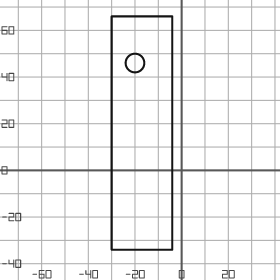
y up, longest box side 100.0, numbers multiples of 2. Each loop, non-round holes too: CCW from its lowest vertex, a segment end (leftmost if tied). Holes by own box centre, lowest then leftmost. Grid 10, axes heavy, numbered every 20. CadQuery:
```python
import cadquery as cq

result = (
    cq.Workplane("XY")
    .moveTo(-30.0, -34.0)
    .lineTo(-4.0, -34.0)
    .lineTo(-4.0, 66.0)
    .lineTo(-30.0, 66.0)
    .close()
    .moveTo(-20.0, 46.0)
    .circle(4.0)
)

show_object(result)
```